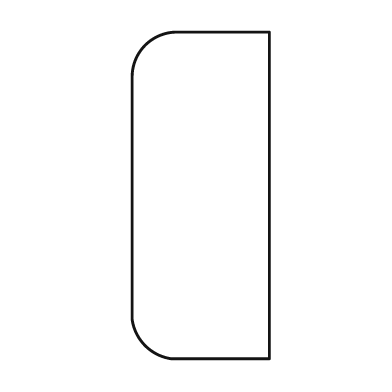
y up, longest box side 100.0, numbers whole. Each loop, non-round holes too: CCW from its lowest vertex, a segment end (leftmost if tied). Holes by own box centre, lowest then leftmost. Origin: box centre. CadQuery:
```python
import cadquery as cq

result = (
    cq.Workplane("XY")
    .moveTo(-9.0, -50.0)
    .lineTo(21.0, -50.0)
    .lineTo(21.0, 50.0)
    .lineTo(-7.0, 50.0)
    .threePointArc((-17.0, 46.0), (-21.0, 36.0))
    .lineTo(-21.0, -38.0)
    .threePointArc((-17.0, -46.0), (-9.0, -50.0))
    .close()
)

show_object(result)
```